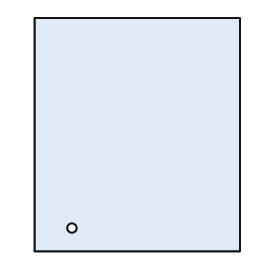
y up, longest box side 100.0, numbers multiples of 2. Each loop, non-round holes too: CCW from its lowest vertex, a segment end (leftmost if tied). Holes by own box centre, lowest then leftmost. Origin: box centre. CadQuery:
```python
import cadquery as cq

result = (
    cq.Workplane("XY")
    .moveTo(-44.0, -50.0)
    .lineTo(44.0, -50.0)
    .lineTo(44.0, 50.0)
    .lineTo(-44.0, 50.0)
    .close()
    .moveTo(-28.0, -40.0)
    .circle(2.0)
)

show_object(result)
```